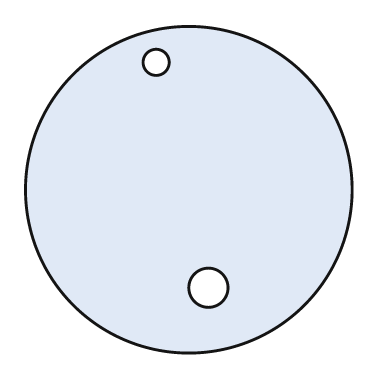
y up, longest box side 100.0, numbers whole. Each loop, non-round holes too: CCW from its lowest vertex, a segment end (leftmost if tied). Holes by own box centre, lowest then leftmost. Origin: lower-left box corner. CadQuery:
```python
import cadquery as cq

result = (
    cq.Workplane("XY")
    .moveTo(50.0, 50.0)
    .circle(50.0)
    .moveTo(56.0, 20.0)
    .circle(6.0)
    .moveTo(40.0, 89.0)
    .circle(4.0)
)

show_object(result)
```